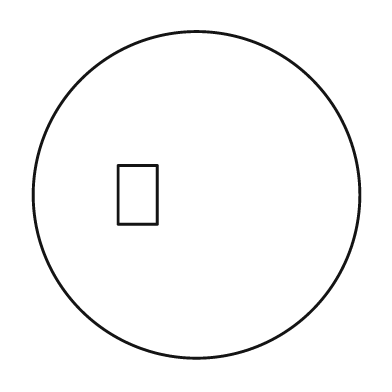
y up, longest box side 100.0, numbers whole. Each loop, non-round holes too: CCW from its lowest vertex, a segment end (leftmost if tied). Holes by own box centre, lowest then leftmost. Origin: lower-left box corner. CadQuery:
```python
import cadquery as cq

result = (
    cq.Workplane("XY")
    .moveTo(50.0, 50.0)
    .circle(50.0)
    .moveTo(26.0, 41.0)
    .lineTo(38.0, 41.0)
    .lineTo(38.0, 59.0)
    .lineTo(26.0, 59.0)
    .close()
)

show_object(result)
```